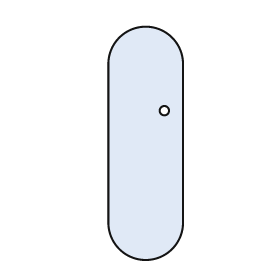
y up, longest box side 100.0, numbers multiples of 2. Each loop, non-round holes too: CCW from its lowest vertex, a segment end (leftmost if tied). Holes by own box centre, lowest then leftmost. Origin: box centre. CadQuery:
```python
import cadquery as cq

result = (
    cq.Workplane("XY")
    .moveTo(-16.0, -34.0)
    .threePointArc((0.0, -50.0), (16.0, -34.0))
    .lineTo(16.0, 34.0)
    .threePointArc((0.0, 50.0), (-16.0, 34.0))
    .close()
    .moveTo(8.0, 14.0)
    .circle(2.0)
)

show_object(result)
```